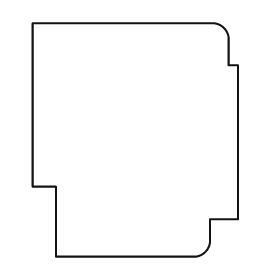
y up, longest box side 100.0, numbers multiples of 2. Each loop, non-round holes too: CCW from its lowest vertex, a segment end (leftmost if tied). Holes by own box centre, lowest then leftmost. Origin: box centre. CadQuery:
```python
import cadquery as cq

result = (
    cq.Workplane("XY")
    .moveTo(-34.0, -50.0)
    .lineTo(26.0, -50.0)
    .threePointArc((30.0, -48.0), (32.0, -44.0))
    .lineTo(32.0, -34.0)
    .lineTo(44.0, -34.0)
    .lineTo(44.0, 32.0)
    .lineTo(40.0, 32.0)
    .lineTo(40.0, 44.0)
    .threePointArc((38.0, 48.0), (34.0, 50.0))
    .lineTo(-44.0, 50.0)
    .lineTo(-44.0, -20.0)
    .lineTo(-34.0, -20.0)
    .close()
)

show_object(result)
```